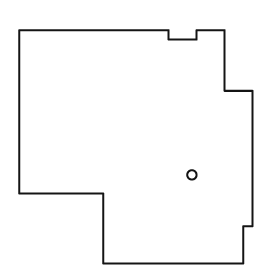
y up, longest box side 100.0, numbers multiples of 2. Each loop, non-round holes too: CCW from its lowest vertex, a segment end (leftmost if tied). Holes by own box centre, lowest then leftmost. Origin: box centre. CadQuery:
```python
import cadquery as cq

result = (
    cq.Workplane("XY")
    .moveTo(-14.0, -50.0)
    .lineTo(46.0, -50.0)
    .lineTo(46.0, -34.0)
    .lineTo(50.0, -34.0)
    .lineTo(50.0, 24.0)
    .lineTo(38.0, 24.0)
    .lineTo(38.0, 50.0)
    .lineTo(26.0, 50.0)
    .lineTo(26.0, 46.0)
    .lineTo(14.0, 46.0)
    .lineTo(14.0, 50.0)
    .lineTo(-50.0, 50.0)
    .lineTo(-50.0, -20.0)
    .lineTo(-14.0, -20.0)
    .close()
    .moveTo(24.0, -12.0)
    .circle(2.0)
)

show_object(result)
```